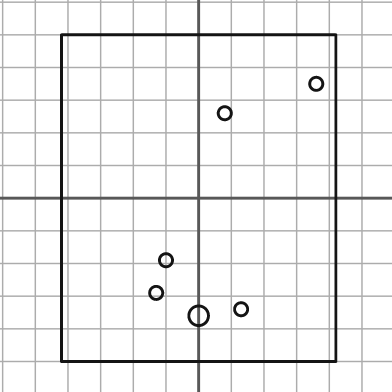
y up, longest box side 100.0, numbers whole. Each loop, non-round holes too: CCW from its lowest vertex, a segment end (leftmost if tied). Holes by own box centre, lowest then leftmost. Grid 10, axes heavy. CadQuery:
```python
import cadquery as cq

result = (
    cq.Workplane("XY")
    .moveTo(-42.0, -50.0)
    .lineTo(42.0, -50.0)
    .lineTo(42.0, 50.0)
    .lineTo(-42.0, 50.0)
    .close()
    .moveTo(0.0, -36.0)
    .circle(3.0)
    .moveTo(13.0, -34.0)
    .circle(2.0)
    .moveTo(-13.0, -29.0)
    .circle(2.0)
    .moveTo(-10.0, -19.0)
    .circle(2.0)
    .moveTo(8.0, 26.0)
    .circle(2.0)
    .moveTo(36.0, 35.0)
    .circle(2.0)
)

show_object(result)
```